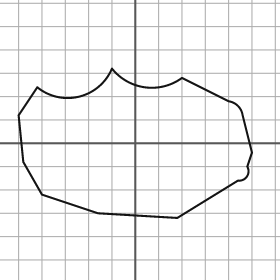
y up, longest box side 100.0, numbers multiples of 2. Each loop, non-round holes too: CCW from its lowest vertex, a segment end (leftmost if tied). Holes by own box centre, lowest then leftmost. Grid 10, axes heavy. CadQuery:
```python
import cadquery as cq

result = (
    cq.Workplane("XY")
    .moveTo(18.0, -32.0)
    .lineTo(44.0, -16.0)
    .threePointArc((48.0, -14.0), (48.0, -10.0))
    .lineTo(50.0, -4.0)
    .lineTo(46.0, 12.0)
    .threePointArc((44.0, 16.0), (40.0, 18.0))
    .lineTo(20.0, 28.0)
    .threePointArc((4.0, 24.0), (-10.0, 32.0))
    .threePointArc((-24.0, 20.0), (-42.0, 24.0))
    .lineTo(-50.0, 12.0)
    .lineTo(-48.0, -8.0)
    .lineTo(-40.0, -22.0)
    .lineTo(-16.0, -30.0)
    .close()
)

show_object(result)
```